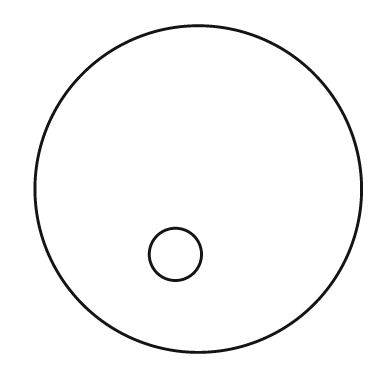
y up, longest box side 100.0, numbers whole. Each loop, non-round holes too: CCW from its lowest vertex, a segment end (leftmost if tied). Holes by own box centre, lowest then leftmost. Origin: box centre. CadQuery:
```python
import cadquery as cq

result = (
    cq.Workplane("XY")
    .moveTo(0.0, 0.0)
    .circle(50.0)
    .moveTo(-7.0, -20.0)
    .circle(8.0)
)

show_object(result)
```